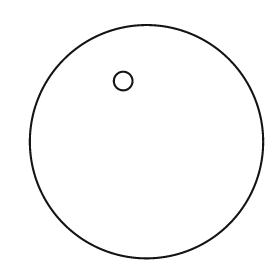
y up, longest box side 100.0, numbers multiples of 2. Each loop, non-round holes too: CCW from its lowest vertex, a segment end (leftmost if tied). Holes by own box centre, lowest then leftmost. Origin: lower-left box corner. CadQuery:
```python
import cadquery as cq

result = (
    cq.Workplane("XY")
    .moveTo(50.0, 50.0)
    .circle(50.0)
    .moveTo(40.0, 76.0)
    .circle(4.0)
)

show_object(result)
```